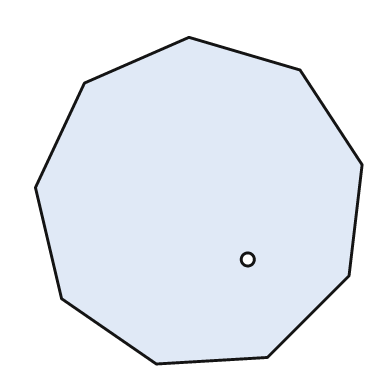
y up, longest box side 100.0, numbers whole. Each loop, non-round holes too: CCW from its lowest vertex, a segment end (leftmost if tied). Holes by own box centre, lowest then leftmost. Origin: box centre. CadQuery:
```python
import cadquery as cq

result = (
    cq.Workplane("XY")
    .moveTo(-13.0, -50.0)
    .lineTo(21.0, -48.0)
    .lineTo(46.0, -23.0)
    .lineTo(50.0, 11.0)
    .lineTo(31.0, 40.0)
    .lineTo(-3.0, 50.0)
    .lineTo(-35.0, 36.0)
    .lineTo(-50.0, 4.0)
    .lineTo(-42.0, -30.0)
    .close()
    .moveTo(15.0, -18.0)
    .circle(2.0)
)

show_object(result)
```